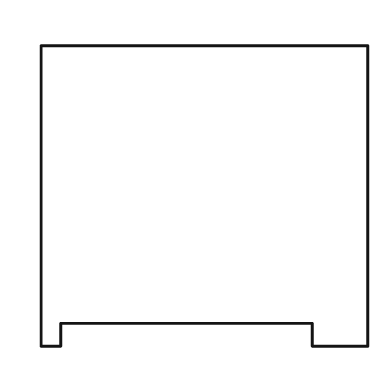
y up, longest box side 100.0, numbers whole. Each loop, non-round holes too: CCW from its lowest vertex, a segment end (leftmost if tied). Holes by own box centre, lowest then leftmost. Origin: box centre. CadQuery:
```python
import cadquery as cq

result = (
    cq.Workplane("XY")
    .moveTo(-50.0, -46.0)
    .lineTo(-44.0, -46.0)
    .lineTo(-44.0, -39.0)
    .lineTo(33.0, -39.0)
    .lineTo(33.0, -46.0)
    .lineTo(50.0, -46.0)
    .lineTo(50.0, 46.0)
    .lineTo(-50.0, 46.0)
    .close()
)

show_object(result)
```